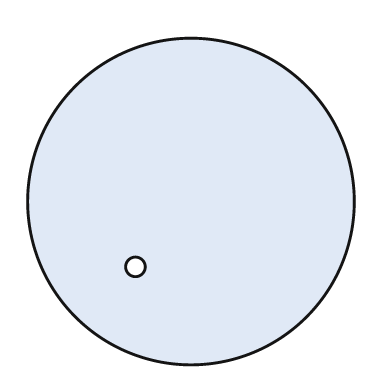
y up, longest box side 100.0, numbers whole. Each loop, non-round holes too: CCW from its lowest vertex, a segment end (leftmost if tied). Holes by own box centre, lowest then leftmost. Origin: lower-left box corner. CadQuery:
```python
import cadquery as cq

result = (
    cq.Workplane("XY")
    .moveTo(50.0, 50.0)
    .circle(50.0)
    .moveTo(33.0, 30.0)
    .circle(3.0)
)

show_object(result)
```